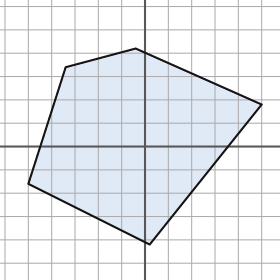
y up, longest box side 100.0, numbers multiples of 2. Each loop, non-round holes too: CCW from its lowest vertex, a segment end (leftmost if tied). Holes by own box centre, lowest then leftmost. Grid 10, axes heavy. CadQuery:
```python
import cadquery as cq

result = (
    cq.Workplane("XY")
    .moveTo(2.0, -42.0)
    .lineTo(50.0, 18.0)
    .lineTo(-4.0, 42.0)
    .lineTo(-34.0, 34.0)
    .lineTo(-50.0, -16.0)
    .close()
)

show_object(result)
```